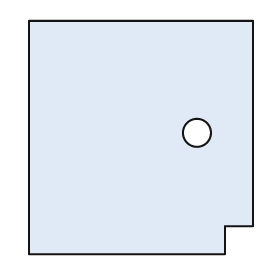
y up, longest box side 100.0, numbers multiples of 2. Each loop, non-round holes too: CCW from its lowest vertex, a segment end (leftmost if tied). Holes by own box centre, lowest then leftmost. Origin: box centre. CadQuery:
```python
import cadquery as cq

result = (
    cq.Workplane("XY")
    .moveTo(-48.0, -50.0)
    .lineTo(36.0, -50.0)
    .lineTo(36.0, -38.0)
    .lineTo(48.0, -38.0)
    .lineTo(48.0, 50.0)
    .lineTo(-48.0, 50.0)
    .close()
    .moveTo(24.0, 2.0)
    .circle(6.0)
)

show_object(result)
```